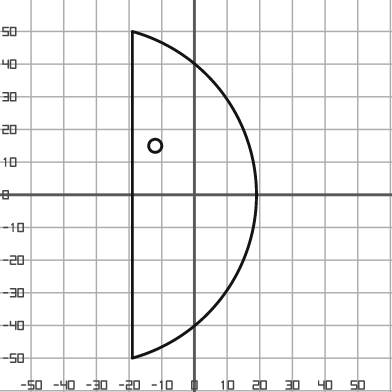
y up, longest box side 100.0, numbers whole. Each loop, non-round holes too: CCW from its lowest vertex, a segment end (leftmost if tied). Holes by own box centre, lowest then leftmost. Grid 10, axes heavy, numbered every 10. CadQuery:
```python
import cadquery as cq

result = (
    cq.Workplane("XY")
    .moveTo(-19.0, -50.0)
    .threePointArc((19.0, 0.0), (-19.0, 50.0))
    .close()
    .moveTo(-12.0, 15.0)
    .circle(2.0)
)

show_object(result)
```